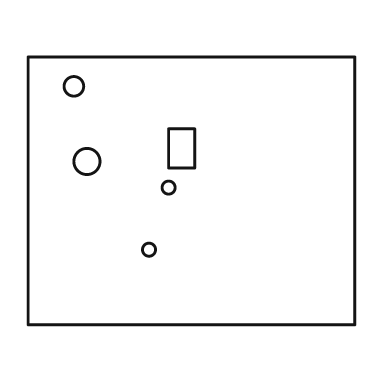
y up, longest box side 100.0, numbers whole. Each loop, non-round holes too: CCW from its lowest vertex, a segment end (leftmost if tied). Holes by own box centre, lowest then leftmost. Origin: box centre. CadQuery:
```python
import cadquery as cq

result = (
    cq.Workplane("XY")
    .moveTo(-50.0, -41.0)
    .lineTo(50.0, -41.0)
    .lineTo(50.0, 41.0)
    .lineTo(-50.0, 41.0)
    .close()
    .moveTo(-13.0, -18.0)
    .circle(2.0)
    .moveTo(-7.0, 1.0)
    .circle(2.0)
    .moveTo(-32.0, 9.0)
    .circle(4.0)
    .moveTo(-7.0, 7.0)
    .lineTo(1.0, 7.0)
    .lineTo(1.0, 19.0)
    .lineTo(-7.0, 19.0)
    .close()
    .moveTo(-36.0, 32.0)
    .circle(3.0)
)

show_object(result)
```